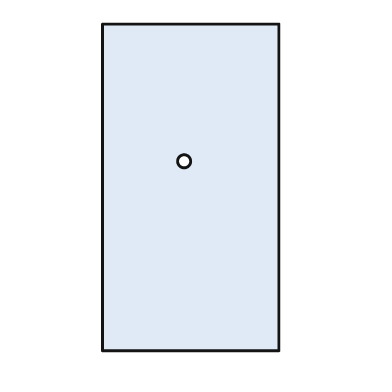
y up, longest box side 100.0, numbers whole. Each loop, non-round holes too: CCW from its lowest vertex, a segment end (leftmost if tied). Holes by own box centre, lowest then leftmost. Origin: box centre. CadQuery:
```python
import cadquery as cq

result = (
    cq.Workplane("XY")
    .moveTo(-27.0, -50.0)
    .lineTo(27.0, -50.0)
    .lineTo(27.0, 50.0)
    .lineTo(-27.0, 50.0)
    .close()
    .moveTo(-2.0, 8.0)
    .circle(2.0)
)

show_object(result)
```